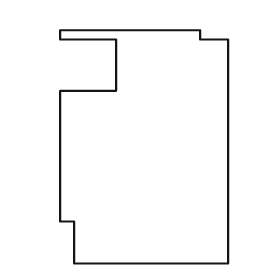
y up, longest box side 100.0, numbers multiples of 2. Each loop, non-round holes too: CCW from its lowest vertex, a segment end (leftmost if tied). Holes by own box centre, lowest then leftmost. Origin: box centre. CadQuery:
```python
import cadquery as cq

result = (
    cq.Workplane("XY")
    .moveTo(-30.0, -50.0)
    .lineTo(36.0, -50.0)
    .lineTo(36.0, 46.0)
    .lineTo(24.0, 46.0)
    .lineTo(24.0, 50.0)
    .lineTo(-36.0, 50.0)
    .lineTo(-36.0, 46.0)
    .lineTo(-12.0, 46.0)
    .lineTo(-12.0, 24.0)
    .lineTo(-36.0, 24.0)
    .lineTo(-36.0, -32.0)
    .lineTo(-30.0, -32.0)
    .close()
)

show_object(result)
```